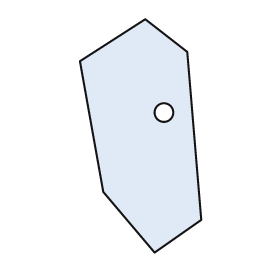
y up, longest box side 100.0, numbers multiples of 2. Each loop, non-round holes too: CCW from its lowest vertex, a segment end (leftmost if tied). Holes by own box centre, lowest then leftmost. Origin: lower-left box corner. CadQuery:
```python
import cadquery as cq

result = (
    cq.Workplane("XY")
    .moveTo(32.0, 0.0)
    .lineTo(52.0, 14.0)
    .lineTo(46.0, 86.0)
    .lineTo(28.0, 100.0)
    .lineTo(0.0, 82.0)
    .lineTo(10.0, 26.0)
    .close()
    .moveTo(36.0, 60.0)
    .circle(4.0)
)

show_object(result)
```